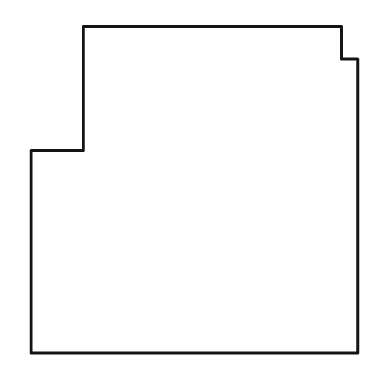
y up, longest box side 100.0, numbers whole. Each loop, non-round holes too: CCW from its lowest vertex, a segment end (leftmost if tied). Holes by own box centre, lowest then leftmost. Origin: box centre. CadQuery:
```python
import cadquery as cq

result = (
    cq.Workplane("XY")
    .moveTo(-50.0, -50.0)
    .lineTo(50.0, -50.0)
    .lineTo(50.0, 40.0)
    .lineTo(45.0, 40.0)
    .lineTo(45.0, 50.0)
    .lineTo(-34.0, 50.0)
    .lineTo(-34.0, 12.0)
    .lineTo(-50.0, 12.0)
    .close()
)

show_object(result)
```